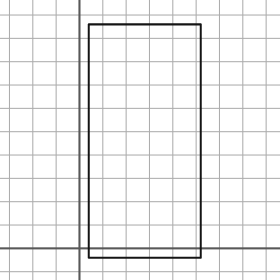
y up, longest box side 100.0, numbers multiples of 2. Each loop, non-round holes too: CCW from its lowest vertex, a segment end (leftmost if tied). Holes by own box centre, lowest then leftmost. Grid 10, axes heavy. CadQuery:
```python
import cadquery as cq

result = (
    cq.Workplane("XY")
    .moveTo(4.0, -4.0)
    .lineTo(52.0, -4.0)
    .lineTo(52.0, 96.0)
    .lineTo(4.0, 96.0)
    .close()
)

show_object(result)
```